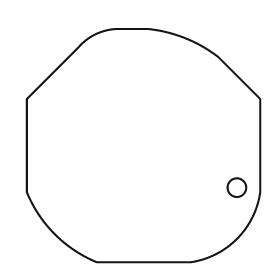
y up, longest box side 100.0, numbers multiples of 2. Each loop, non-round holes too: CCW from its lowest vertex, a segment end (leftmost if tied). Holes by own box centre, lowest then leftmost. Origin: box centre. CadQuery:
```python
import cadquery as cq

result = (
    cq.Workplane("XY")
    .moveTo(-20.0, -50.0)
    .lineTo(20.0, -50.0)
    .threePointArc((40.0, -40.0), (50.0, -20.0))
    .lineTo(50.0, 20.0)
    .lineTo(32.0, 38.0)
    .threePointArc((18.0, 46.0), (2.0, 50.0))
    .lineTo(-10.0, 50.0)
    .threePointArc((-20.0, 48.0), (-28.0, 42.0))
    .lineTo(-50.0, 20.0)
    .lineTo(-50.0, -20.0)
    .threePointArc((-38.0, -38.0), (-20.0, -50.0))
    .close()
    .moveTo(40.0, -18.0)
    .circle(4.0)
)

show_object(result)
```